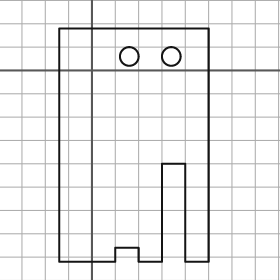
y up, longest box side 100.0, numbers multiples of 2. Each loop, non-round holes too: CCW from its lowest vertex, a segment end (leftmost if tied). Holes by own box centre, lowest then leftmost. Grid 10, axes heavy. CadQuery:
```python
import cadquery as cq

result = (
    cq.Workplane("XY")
    .moveTo(-14.0, -82.0)
    .lineTo(10.0, -82.0)
    .lineTo(10.0, -76.0)
    .lineTo(20.0, -76.0)
    .lineTo(20.0, -82.0)
    .lineTo(30.0, -82.0)
    .lineTo(30.0, -40.0)
    .lineTo(40.0, -40.0)
    .lineTo(40.0, -82.0)
    .lineTo(50.0, -82.0)
    .lineTo(50.0, 18.0)
    .lineTo(-14.0, 18.0)
    .close()
    .moveTo(16.0, 6.0)
    .circle(4.0)
    .moveTo(34.0, 6.0)
    .circle(4.0)
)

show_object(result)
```